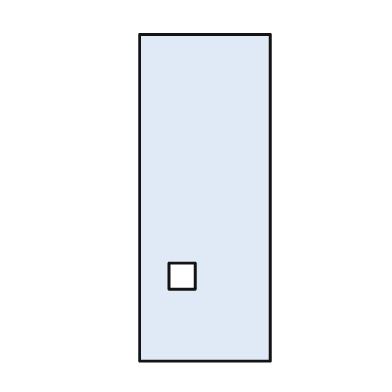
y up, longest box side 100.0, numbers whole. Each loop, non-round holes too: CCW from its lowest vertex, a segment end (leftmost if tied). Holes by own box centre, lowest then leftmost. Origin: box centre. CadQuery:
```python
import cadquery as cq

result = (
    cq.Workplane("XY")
    .moveTo(-20.0, -50.0)
    .lineTo(20.0, -50.0)
    .lineTo(20.0, 50.0)
    .lineTo(-20.0, 50.0)
    .close()
    .moveTo(-11.0, -28.0)
    .lineTo(-3.0, -28.0)
    .lineTo(-3.0, -20.0)
    .lineTo(-11.0, -20.0)
    .close()
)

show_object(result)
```